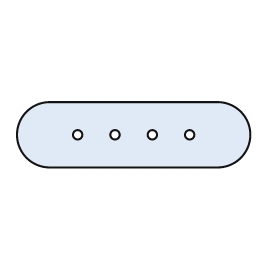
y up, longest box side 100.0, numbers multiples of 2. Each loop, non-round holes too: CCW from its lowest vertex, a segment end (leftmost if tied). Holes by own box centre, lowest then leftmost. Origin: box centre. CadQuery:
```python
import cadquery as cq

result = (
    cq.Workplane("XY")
    .moveTo(-36.0, -14.0)
    .lineTo(36.0, -14.0)
    .threePointArc((50.0, 0.0), (36.0, 14.0))
    .lineTo(-36.0, 14.0)
    .threePointArc((-50.0, 0.0), (-36.0, -14.0))
    .close()
    .moveTo(-24.0, 0.0)
    .circle(2.0)
    .moveTo(-8.0, 0.0)
    .circle(2.0)
    .moveTo(8.0, 0.0)
    .circle(2.0)
    .moveTo(24.0, 0.0)
    .circle(2.0)
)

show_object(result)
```